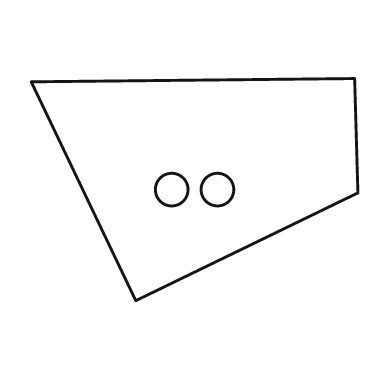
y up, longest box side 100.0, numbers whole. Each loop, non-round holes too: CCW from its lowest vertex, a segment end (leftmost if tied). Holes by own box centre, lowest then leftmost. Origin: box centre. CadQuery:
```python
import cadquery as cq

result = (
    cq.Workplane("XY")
    .moveTo(-18.0, -34.0)
    .lineTo(50.0, -1.0)
    .lineTo(49.0, 34.0)
    .lineTo(-50.0, 33.0)
    .close()
    .moveTo(-7.0, 0.0)
    .circle(5.0)
    .moveTo(7.0, 0.0)
    .circle(5.0)
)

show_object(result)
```